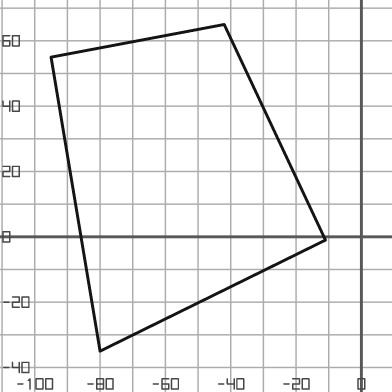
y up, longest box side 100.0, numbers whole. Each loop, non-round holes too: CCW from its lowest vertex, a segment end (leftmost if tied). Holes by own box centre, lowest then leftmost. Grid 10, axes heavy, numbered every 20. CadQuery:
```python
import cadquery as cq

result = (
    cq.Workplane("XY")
    .moveTo(-80.0, -35.0)
    .lineTo(-11.0, -1.0)
    .lineTo(-42.0, 65.0)
    .lineTo(-95.0, 55.0)
    .close()
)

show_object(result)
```